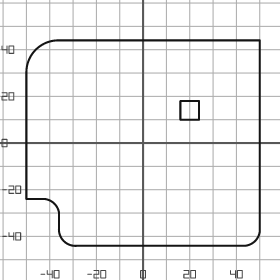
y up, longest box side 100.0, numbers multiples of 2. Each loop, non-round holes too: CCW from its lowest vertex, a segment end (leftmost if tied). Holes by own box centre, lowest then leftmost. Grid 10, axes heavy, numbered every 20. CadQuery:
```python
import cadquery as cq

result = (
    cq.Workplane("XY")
    .moveTo(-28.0, -44.0)
    .lineTo(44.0, -44.0)
    .threePointArc((48.0, -42.0), (50.0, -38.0))
    .lineTo(50.0, 44.0)
    .lineTo(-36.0, 44.0)
    .threePointArc((-46.0, 40.0), (-50.0, 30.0))
    .lineTo(-50.0, -24.0)
    .lineTo(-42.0, -24.0)
    .threePointArc((-38.0, -26.0), (-36.0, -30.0))
    .lineTo(-36.0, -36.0)
    .threePointArc((-34.0, -42.0), (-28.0, -44.0))
    .close()
    .moveTo(16.0, 10.0)
    .lineTo(24.0, 10.0)
    .lineTo(24.0, 18.0)
    .lineTo(16.0, 18.0)
    .close()
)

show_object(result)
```